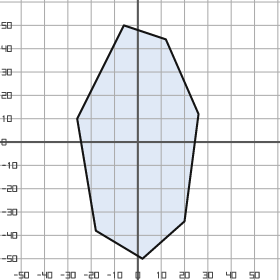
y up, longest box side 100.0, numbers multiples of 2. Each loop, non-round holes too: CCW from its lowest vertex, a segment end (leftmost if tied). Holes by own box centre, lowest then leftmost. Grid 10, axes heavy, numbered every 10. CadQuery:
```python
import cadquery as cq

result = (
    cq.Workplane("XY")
    .moveTo(2.0, -50.0)
    .lineTo(20.0, -34.0)
    .lineTo(26.0, 12.0)
    .lineTo(12.0, 44.0)
    .lineTo(-6.0, 50.0)
    .lineTo(-26.0, 10.0)
    .lineTo(-18.0, -38.0)
    .close()
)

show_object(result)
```